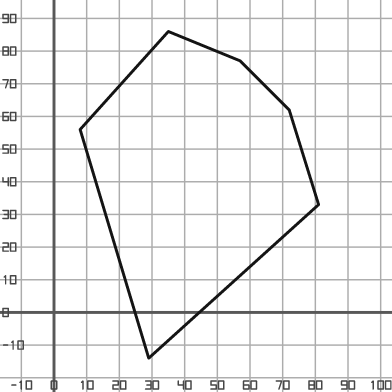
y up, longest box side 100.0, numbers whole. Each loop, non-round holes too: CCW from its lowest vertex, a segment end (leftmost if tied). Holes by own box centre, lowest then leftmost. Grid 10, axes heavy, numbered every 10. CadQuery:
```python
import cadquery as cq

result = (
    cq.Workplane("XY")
    .moveTo(29.0, -14.0)
    .lineTo(81.0, 33.0)
    .lineTo(72.0, 62.0)
    .lineTo(57.0, 77.0)
    .lineTo(35.0, 86.0)
    .lineTo(8.0, 56.0)
    .close()
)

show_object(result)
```